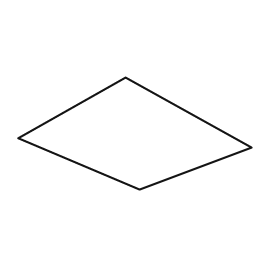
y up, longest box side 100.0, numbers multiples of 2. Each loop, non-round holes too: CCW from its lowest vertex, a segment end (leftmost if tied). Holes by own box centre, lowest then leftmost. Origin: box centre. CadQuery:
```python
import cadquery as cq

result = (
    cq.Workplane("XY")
    .moveTo(2.0, -24.0)
    .lineTo(50.0, -6.0)
    .lineTo(-4.0, 24.0)
    .lineTo(-50.0, -2.0)
    .close()
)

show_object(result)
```